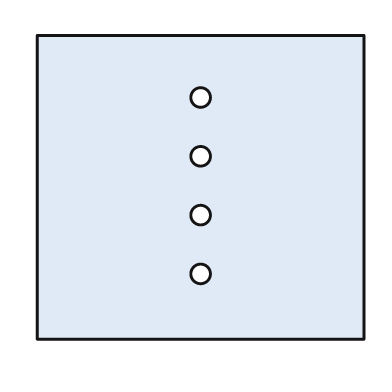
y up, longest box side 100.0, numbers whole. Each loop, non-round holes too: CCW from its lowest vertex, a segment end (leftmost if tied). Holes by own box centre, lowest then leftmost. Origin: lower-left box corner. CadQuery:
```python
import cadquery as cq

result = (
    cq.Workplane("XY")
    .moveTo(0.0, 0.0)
    .lineTo(100.0, 0.0)
    .lineTo(100.0, 93.0)
    .lineTo(0.0, 93.0)
    .close()
    .moveTo(50.0, 20.0)
    .circle(3.0)
    .moveTo(50.0, 38.0)
    .circle(3.0)
    .moveTo(50.0, 56.0)
    .circle(3.0)
    .moveTo(50.0, 74.0)
    .circle(3.0)
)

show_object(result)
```